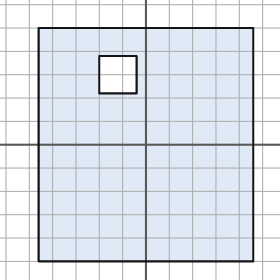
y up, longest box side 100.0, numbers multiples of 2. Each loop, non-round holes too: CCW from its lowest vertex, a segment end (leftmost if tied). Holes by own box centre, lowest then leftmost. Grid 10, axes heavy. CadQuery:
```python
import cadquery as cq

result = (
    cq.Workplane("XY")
    .moveTo(-46.0, -50.0)
    .lineTo(46.0, -50.0)
    .lineTo(46.0, 50.0)
    .lineTo(-46.0, 50.0)
    .close()
    .moveTo(-20.0, 22.0)
    .lineTo(-4.0, 22.0)
    .lineTo(-4.0, 38.0)
    .lineTo(-20.0, 38.0)
    .close()
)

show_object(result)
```